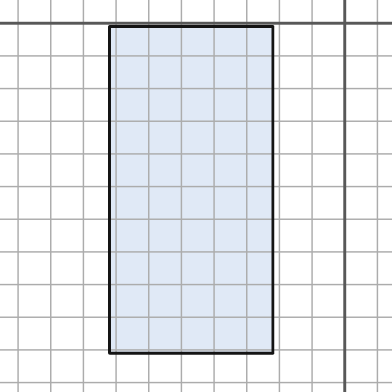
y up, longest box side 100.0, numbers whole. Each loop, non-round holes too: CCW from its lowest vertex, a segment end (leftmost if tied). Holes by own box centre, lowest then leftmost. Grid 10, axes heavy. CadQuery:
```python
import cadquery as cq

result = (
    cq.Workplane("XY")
    .moveTo(-72.0, -101.0)
    .lineTo(-22.0, -101.0)
    .lineTo(-22.0, -1.0)
    .lineTo(-72.0, -1.0)
    .close()
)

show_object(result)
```